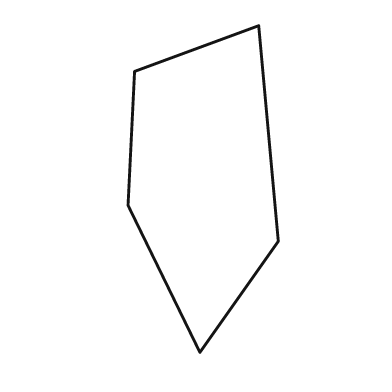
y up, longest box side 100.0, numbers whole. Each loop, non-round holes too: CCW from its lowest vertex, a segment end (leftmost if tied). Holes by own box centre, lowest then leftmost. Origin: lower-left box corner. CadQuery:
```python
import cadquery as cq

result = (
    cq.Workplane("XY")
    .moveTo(22.0, 0.0)
    .lineTo(46.0, 34.0)
    .lineTo(40.0, 100.0)
    .lineTo(2.0, 86.0)
    .lineTo(0.0, 45.0)
    .close()
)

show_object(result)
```